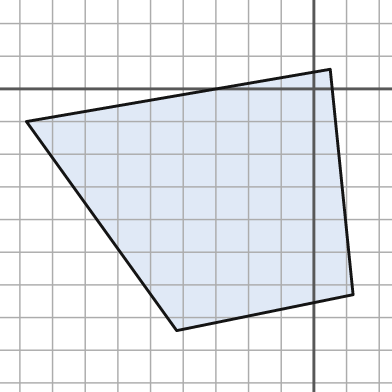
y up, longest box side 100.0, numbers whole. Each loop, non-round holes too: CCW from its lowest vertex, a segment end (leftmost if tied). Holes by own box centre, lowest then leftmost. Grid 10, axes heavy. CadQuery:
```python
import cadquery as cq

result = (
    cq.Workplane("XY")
    .moveTo(-42.0, -74.0)
    .lineTo(12.0, -63.0)
    .lineTo(5.0, 6.0)
    .lineTo(-88.0, -10.0)
    .close()
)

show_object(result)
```